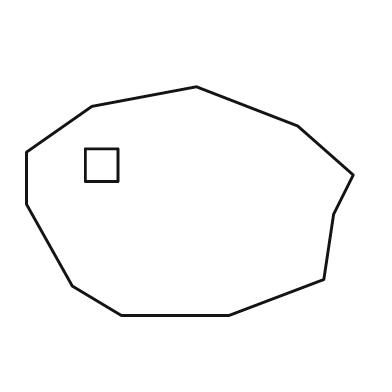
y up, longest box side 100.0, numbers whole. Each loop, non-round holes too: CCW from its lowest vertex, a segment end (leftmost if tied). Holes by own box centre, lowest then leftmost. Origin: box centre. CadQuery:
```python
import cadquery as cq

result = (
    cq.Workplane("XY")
    .moveTo(-21.0, -35.0)
    .lineTo(12.0, -35.0)
    .lineTo(41.0, -24.0)
    .lineTo(44.0, -4.0)
    .lineTo(50.0, 8.0)
    .lineTo(33.0, 23.0)
    .lineTo(2.0, 35.0)
    .lineTo(-30.0, 29.0)
    .lineTo(-50.0, 15.0)
    .lineTo(-50.0, -1.0)
    .lineTo(-36.0, -26.0)
    .close()
    .moveTo(-32.0, 6.0)
    .lineTo(-22.0, 6.0)
    .lineTo(-22.0, 16.0)
    .lineTo(-32.0, 16.0)
    .close()
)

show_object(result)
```